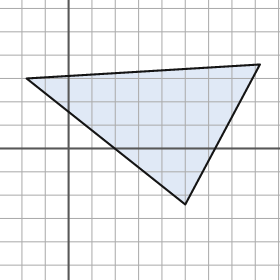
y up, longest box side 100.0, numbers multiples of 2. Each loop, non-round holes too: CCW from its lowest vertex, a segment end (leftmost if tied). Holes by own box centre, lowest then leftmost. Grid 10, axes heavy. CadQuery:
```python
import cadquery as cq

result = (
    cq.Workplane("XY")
    .moveTo(50.0, -24.0)
    .lineTo(82.0, 36.0)
    .lineTo(-18.0, 30.0)
    .close()
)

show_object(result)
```